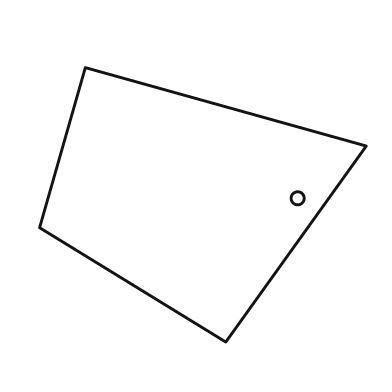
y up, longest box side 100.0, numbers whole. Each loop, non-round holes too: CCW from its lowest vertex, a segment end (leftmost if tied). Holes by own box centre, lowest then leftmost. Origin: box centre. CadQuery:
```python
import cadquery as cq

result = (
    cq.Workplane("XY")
    .moveTo(7.0, -42.0)
    .lineTo(50.0, 18.0)
    .lineTo(-36.0, 42.0)
    .lineTo(-50.0, -7.0)
    .close()
    .moveTo(29.0, 2.0)
    .circle(2.0)
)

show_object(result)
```